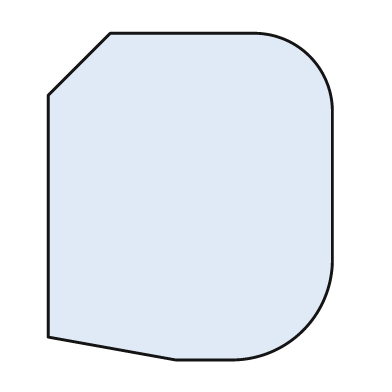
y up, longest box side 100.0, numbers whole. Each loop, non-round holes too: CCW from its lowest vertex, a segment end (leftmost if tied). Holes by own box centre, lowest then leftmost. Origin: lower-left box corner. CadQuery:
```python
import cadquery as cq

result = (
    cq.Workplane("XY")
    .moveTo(39.0, 0.0)
    .lineTo(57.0, 0.0)
    .threePointArc((78.0, 9.0), (87.0, 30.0))
    .lineTo(87.0, 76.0)
    .threePointArc((80.0, 93.0), (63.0, 100.0))
    .lineTo(19.0, 100.0)
    .lineTo(0.0, 81.0)
    .lineTo(0.0, 7.0)
    .close()
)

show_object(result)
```